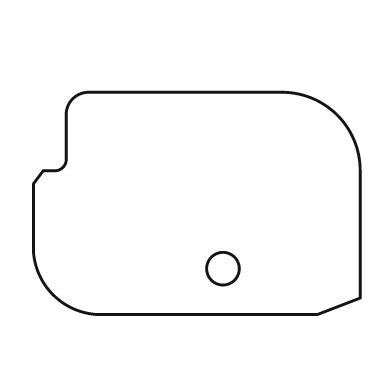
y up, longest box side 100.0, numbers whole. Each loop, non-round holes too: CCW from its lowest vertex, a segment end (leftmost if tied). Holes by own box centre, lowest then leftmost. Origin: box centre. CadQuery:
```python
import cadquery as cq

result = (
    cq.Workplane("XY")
    .moveTo(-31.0, -34.0)
    .lineTo(37.0, -34.0)
    .lineTo(50.0, -29.0)
    .lineTo(50.0, 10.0)
    .threePointArc((43.0, 27.0), (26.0, 34.0))
    .lineTo(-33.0, 34.0)
    .threePointArc((-38.0, 32.0), (-40.0, 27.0))
    .lineTo(-40.0, 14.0)
    .threePointArc((-41.0, 11.0), (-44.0, 10.0))
    .lineTo(-47.0, 10.0)
    .lineTo(-50.0, 6.0)
    .lineTo(-50.0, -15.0)
    .threePointArc((-44.0, -28.0), (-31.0, -34.0))
    .close()
    .moveTo(8.0, -20.0)
    .circle(5.0)
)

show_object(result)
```